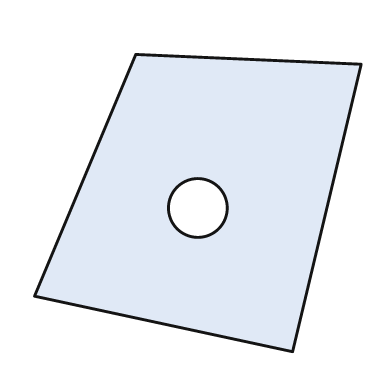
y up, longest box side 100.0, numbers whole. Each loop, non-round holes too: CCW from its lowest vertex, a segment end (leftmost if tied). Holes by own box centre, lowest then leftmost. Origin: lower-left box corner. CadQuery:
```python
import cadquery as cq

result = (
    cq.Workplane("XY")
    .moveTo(79.0, 0.0)
    .lineTo(100.0, 88.0)
    .lineTo(31.0, 91.0)
    .lineTo(0.0, 17.0)
    .close()
    .moveTo(50.0, 44.0)
    .circle(9.0)
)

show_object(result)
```